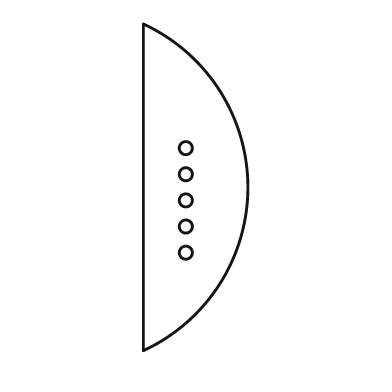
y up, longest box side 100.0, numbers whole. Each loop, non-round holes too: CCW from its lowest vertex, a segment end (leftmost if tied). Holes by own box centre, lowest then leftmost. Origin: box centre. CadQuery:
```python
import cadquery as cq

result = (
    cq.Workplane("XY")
    .moveTo(-16.0, -50.0)
    .threePointArc((16.0, 0.0), (-16.0, 50.0))
    .close()
    .moveTo(-3.0, -20.0)
    .circle(2.0)
    .moveTo(-3.0, -12.0)
    .circle(2.0)
    .moveTo(-3.0, -4.0)
    .circle(2.0)
    .moveTo(-3.0, 4.0)
    .circle(2.0)
    .moveTo(-3.0, 12.0)
    .circle(2.0)
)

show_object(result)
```